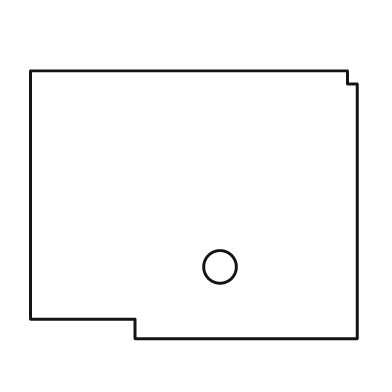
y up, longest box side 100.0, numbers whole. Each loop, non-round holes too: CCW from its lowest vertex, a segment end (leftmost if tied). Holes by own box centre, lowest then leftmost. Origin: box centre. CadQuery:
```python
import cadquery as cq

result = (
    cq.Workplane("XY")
    .moveTo(-18.0, -41.0)
    .lineTo(50.0, -41.0)
    .lineTo(50.0, 37.0)
    .lineTo(47.0, 37.0)
    .lineTo(47.0, 41.0)
    .lineTo(-50.0, 41.0)
    .lineTo(-50.0, -35.0)
    .lineTo(-18.0, -35.0)
    .close()
    .moveTo(8.0, -19.0)
    .circle(5.0)
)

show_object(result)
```